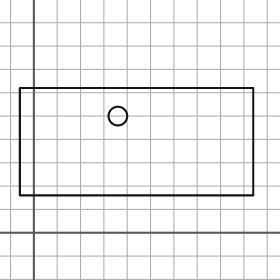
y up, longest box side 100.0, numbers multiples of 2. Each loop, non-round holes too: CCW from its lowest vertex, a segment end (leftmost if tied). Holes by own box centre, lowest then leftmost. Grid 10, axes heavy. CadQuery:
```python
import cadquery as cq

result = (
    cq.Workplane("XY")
    .moveTo(-6.0, 16.0)
    .lineTo(94.0, 16.0)
    .lineTo(94.0, 62.0)
    .lineTo(-6.0, 62.0)
    .close()
    .moveTo(36.0, 50.0)
    .circle(4.0)
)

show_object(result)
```